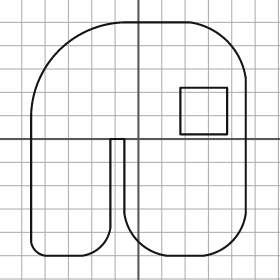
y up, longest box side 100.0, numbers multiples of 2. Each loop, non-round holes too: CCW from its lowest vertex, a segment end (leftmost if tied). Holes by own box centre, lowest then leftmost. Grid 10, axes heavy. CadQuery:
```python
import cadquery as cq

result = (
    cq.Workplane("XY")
    .moveTo(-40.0, -50.0)
    .lineTo(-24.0, -50.0)
    .threePointArc((-16.0, -46.0), (-12.0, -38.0))
    .lineTo(-12.0, 0.0)
    .lineTo(-6.0, 0.0)
    .lineTo(-6.0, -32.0)
    .threePointArc((0.0, -44.0), (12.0, -50.0))
    .lineTo(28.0, -50.0)
    .threePointArc((40.0, -44.0), (46.0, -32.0))
    .lineTo(46.0, 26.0)
    .threePointArc((38.0, 42.0), (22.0, 50.0))
    .lineTo(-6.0, 50.0)
    .threePointArc((-34.0, 38.0), (-46.0, 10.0))
    .lineTo(-46.0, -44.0)
    .threePointArc((-44.0, -48.0), (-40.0, -50.0))
    .close()
    .moveTo(18.0, 2.0)
    .lineTo(38.0, 2.0)
    .lineTo(38.0, 22.0)
    .lineTo(18.0, 22.0)
    .close()
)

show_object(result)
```